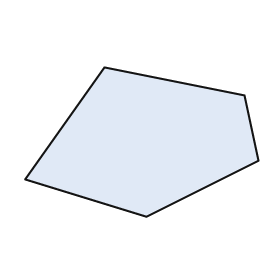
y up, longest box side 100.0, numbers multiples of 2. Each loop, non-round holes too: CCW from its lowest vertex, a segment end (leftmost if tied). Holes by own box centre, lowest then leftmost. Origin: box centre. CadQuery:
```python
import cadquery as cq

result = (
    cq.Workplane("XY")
    .moveTo(2.0, -32.0)
    .lineTo(50.0, -8.0)
    .lineTo(44.0, 20.0)
    .lineTo(-16.0, 32.0)
    .lineTo(-50.0, -16.0)
    .close()
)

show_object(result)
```